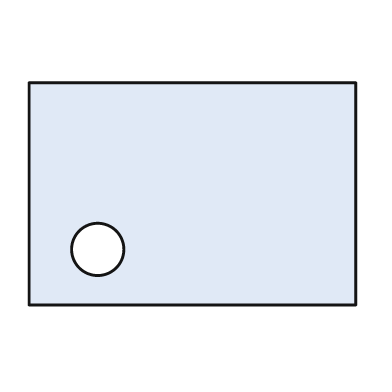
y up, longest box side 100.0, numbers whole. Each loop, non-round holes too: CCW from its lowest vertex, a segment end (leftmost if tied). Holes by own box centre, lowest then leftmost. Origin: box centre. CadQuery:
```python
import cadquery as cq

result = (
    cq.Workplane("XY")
    .moveTo(-50.0, -34.0)
    .lineTo(50.0, -34.0)
    .lineTo(50.0, 34.0)
    .lineTo(-50.0, 34.0)
    .close()
    .moveTo(-29.0, -17.0)
    .circle(8.0)
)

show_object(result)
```